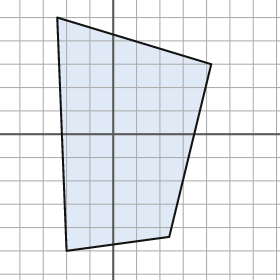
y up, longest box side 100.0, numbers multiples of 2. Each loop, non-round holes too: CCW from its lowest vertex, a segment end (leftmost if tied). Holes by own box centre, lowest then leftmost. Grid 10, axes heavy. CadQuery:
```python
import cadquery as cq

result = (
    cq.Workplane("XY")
    .moveTo(-20.0, -50.0)
    .lineTo(24.0, -44.0)
    .lineTo(42.0, 30.0)
    .lineTo(-24.0, 50.0)
    .close()
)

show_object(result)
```